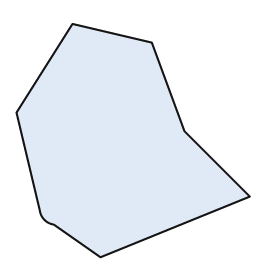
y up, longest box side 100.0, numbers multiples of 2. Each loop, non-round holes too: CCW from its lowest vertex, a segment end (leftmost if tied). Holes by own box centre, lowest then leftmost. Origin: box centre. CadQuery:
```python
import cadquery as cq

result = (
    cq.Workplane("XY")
    .moveTo(-14.0, -50.0)
    .lineTo(50.0, -24.0)
    .lineTo(22.0, 4.0)
    .lineTo(8.0, 42.0)
    .lineTo(-26.0, 50.0)
    .lineTo(-50.0, 12.0)
    .lineTo(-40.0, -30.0)
    .threePointArc((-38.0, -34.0), (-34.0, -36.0))
    .close()
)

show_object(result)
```